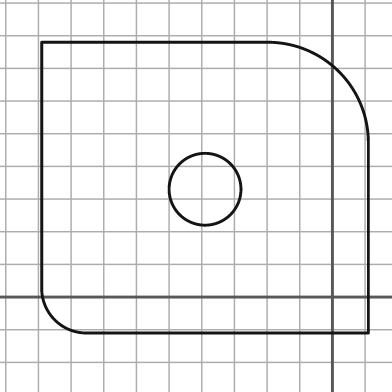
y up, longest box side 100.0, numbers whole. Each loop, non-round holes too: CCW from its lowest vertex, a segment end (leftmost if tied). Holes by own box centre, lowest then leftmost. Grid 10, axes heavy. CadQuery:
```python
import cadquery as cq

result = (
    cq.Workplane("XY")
    .moveTo(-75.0, -11.0)
    .lineTo(11.0, -11.0)
    .lineTo(11.0, 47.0)
    .threePointArc((2.0, 69.0), (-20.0, 78.0))
    .lineTo(-89.0, 78.0)
    .lineTo(-89.0, 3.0)
    .threePointArc((-85.0, -7.0), (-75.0, -11.0))
    .close()
    .moveTo(-39.0, 33.0)
    .circle(11.0)
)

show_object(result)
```